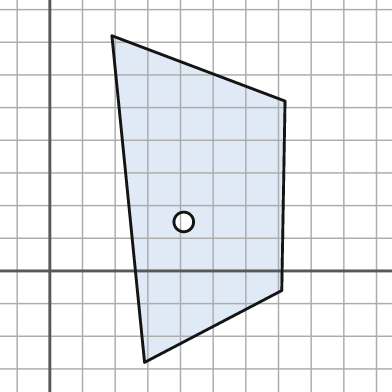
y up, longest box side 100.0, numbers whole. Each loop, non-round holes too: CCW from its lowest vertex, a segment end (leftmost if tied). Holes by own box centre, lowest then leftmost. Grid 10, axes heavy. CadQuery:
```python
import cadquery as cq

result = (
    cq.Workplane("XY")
    .moveTo(29.0, -28.0)
    .lineTo(71.0, -6.0)
    .lineTo(72.0, 52.0)
    .lineTo(19.0, 72.0)
    .close()
    .moveTo(41.0, 15.0)
    .circle(3.0)
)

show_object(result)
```